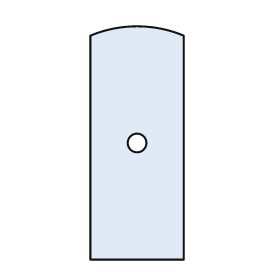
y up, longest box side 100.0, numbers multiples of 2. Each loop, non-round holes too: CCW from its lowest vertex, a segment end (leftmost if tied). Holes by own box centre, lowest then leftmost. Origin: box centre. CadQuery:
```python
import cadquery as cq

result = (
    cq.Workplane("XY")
    .moveTo(-20.0, -50.0)
    .lineTo(20.0, -50.0)
    .lineTo(20.0, 46.0)
    .threePointArc((0.0, 50.0), (-20.0, 46.0))
    .close()
    .moveTo(0.0, 0.0)
    .circle(4.0)
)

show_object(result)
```